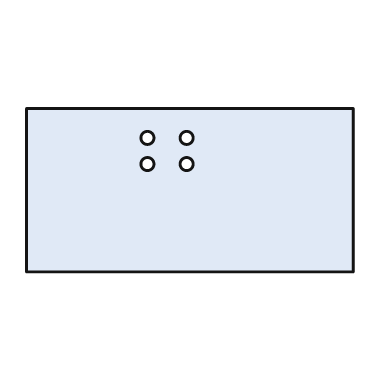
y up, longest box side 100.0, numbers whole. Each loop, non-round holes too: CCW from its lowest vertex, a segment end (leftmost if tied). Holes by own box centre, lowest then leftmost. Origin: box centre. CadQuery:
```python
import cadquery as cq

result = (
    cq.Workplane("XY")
    .moveTo(-50.0, -25.0)
    .lineTo(50.0, -25.0)
    .lineTo(50.0, 25.0)
    .lineTo(-50.0, 25.0)
    .close()
    .moveTo(-13.0, 8.0)
    .circle(2.0)
    .moveTo(-1.0, 8.0)
    .circle(2.0)
    .moveTo(-13.0, 16.0)
    .circle(2.0)
    .moveTo(-1.0, 16.0)
    .circle(2.0)
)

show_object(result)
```